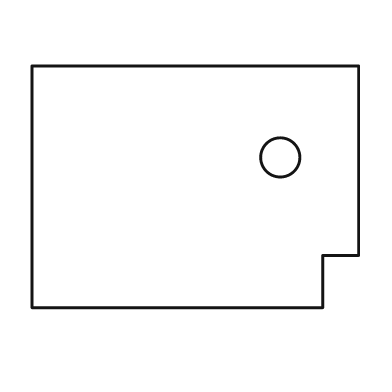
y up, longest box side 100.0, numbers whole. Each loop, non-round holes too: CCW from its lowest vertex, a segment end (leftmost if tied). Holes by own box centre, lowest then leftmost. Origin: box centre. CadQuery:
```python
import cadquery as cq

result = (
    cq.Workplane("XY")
    .moveTo(-50.0, -37.0)
    .lineTo(39.0, -37.0)
    .lineTo(39.0, -21.0)
    .lineTo(50.0, -21.0)
    .lineTo(50.0, 37.0)
    .lineTo(-50.0, 37.0)
    .close()
    .moveTo(26.0, 9.0)
    .circle(6.0)
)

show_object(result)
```